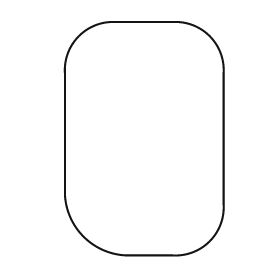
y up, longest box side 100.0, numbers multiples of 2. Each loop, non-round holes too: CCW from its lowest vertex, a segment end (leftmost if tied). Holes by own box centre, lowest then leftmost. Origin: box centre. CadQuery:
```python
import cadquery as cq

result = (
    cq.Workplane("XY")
    .moveTo(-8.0, -50.0)
    .lineTo(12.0, -50.0)
    .threePointArc((28.0, -44.0), (34.0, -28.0))
    .lineTo(34.0, 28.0)
    .threePointArc((28.0, 44.0), (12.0, 50.0))
    .lineTo(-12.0, 50.0)
    .threePointArc((-28.0, 44.0), (-34.0, 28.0))
    .lineTo(-34.0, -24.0)
    .threePointArc((-26.0, -42.0), (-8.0, -50.0))
    .close()
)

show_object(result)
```